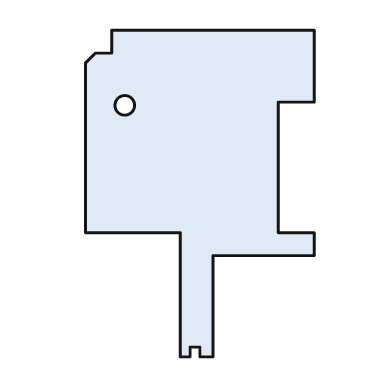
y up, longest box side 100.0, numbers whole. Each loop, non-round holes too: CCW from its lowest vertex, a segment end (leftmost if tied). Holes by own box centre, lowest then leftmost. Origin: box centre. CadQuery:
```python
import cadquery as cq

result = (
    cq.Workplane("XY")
    .moveTo(-6.0, -50.0)
    .lineTo(-3.0, -50.0)
    .lineTo(-3.0, -47.0)
    .lineTo(0.0, -47.0)
    .lineTo(0.0, -50.0)
    .lineTo(4.0, -50.0)
    .lineTo(4.0, -19.0)
    .lineTo(35.0, -19.0)
    .lineTo(35.0, -12.0)
    .lineTo(24.0, -12.0)
    .lineTo(24.0, 28.0)
    .lineTo(35.0, 28.0)
    .lineTo(35.0, 50.0)
    .lineTo(-27.0, 50.0)
    .lineTo(-27.0, 43.0)
    .lineTo(-32.0, 43.0)
    .lineTo(-35.0, 40.0)
    .lineTo(-35.0, -12.0)
    .lineTo(-6.0, -12.0)
    .close()
    .moveTo(-23.0, 27.0)
    .circle(3.0)
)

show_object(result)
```